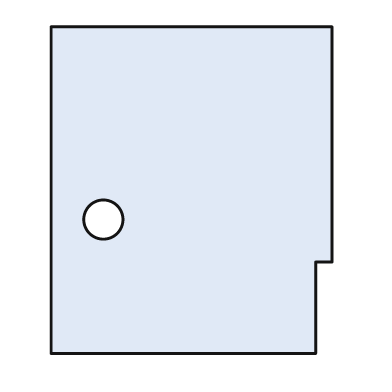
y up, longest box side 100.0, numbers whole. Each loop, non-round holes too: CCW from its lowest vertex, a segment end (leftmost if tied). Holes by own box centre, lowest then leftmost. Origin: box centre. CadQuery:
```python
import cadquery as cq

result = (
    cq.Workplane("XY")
    .moveTo(-43.0, -50.0)
    .lineTo(38.0, -50.0)
    .lineTo(38.0, -22.0)
    .lineTo(43.0, -22.0)
    .lineTo(43.0, 50.0)
    .lineTo(-43.0, 50.0)
    .close()
    .moveTo(-27.0, -9.0)
    .circle(6.0)
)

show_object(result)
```